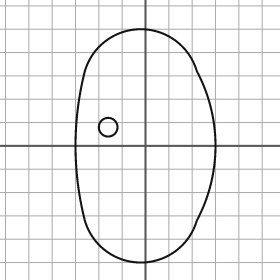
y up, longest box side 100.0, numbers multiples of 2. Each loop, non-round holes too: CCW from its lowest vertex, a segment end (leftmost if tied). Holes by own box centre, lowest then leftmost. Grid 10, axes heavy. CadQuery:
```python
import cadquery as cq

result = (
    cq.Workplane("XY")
    .moveTo(-26.0, -32.0)
    .threePointArc((-2.0, -50.0), (22.0, -32.0))
    .threePointArc((30.0, 0.0), (22.0, 32.0))
    .threePointArc((-2.0, 50.0), (-26.0, 32.0))
    .threePointArc((-30.0, 0.0), (-26.0, -32.0))
    .close()
    .moveTo(-16.0, 8.0)
    .circle(4.0)
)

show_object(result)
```